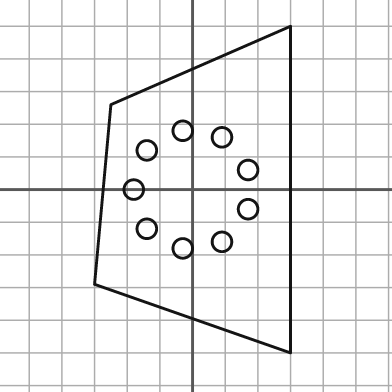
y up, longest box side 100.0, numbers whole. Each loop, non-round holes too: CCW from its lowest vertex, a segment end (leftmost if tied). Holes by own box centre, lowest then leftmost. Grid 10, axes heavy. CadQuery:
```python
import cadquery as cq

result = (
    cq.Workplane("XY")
    .moveTo(30.0, -50.0)
    .lineTo(30.0, 50.0)
    .lineTo(-25.0, 26.0)
    .lineTo(-30.0, -29.0)
    .close()
    .moveTo(-3.0, -18.0)
    .circle(3.0)
    .moveTo(9.0, -16.0)
    .circle(3.0)
    .moveTo(-14.0, -12.0)
    .circle(3.0)
    .moveTo(17.0, -6.0)
    .circle(3.0)
    .moveTo(-18.0, 0.0)
    .circle(3.0)
    .moveTo(17.0, 6.0)
    .circle(3.0)
    .moveTo(-14.0, 12.0)
    .circle(3.0)
    .moveTo(9.0, 16.0)
    .circle(3.0)
    .moveTo(-3.0, 18.0)
    .circle(3.0)
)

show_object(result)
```